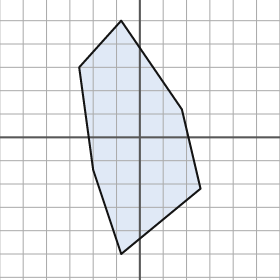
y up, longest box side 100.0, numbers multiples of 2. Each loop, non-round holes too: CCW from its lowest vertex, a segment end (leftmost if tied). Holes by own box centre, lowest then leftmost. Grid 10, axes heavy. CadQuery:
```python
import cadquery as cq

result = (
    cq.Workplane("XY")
    .moveTo(-8.0, -50.0)
    .lineTo(26.0, -22.0)
    .lineTo(18.0, 12.0)
    .lineTo(-8.0, 50.0)
    .lineTo(-26.0, 30.0)
    .lineTo(-20.0, -14.0)
    .close()
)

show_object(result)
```